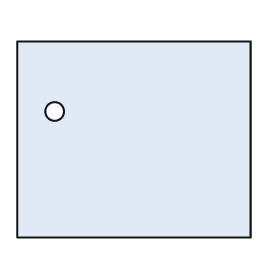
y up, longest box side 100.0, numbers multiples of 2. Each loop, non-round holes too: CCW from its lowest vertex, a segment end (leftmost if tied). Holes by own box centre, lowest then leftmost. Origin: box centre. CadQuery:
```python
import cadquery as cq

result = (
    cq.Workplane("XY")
    .moveTo(-50.0, -42.0)
    .lineTo(50.0, -42.0)
    .lineTo(50.0, 42.0)
    .lineTo(-50.0, 42.0)
    .close()
    .moveTo(-34.0, 12.0)
    .circle(4.0)
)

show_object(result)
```